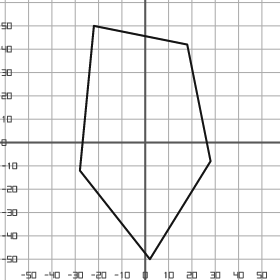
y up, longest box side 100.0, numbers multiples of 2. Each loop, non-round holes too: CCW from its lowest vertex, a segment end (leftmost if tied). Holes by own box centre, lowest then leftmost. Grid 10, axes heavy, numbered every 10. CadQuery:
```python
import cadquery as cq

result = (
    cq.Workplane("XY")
    .moveTo(2.0, -50.0)
    .lineTo(28.0, -8.0)
    .lineTo(18.0, 42.0)
    .lineTo(-22.0, 50.0)
    .lineTo(-28.0, -12.0)
    .close()
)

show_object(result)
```